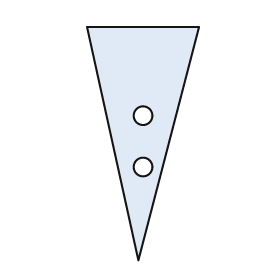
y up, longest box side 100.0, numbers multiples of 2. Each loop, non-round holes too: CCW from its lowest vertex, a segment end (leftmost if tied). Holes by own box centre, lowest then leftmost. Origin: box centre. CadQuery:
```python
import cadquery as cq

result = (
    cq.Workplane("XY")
    .moveTo(-2.0, -50.0)
    .lineTo(24.0, 50.0)
    .lineTo(-24.0, 50.0)
    .close()
    .moveTo(0.0, -10.0)
    .circle(4.0)
    .moveTo(0.0, 12.0)
    .circle(4.0)
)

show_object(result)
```